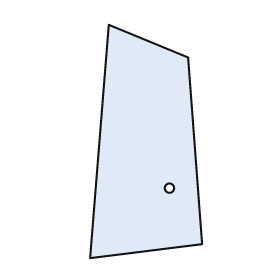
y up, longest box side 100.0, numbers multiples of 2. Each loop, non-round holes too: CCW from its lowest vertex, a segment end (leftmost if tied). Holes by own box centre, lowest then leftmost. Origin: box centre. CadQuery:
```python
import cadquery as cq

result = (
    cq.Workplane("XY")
    .moveTo(-24.0, -50.0)
    .lineTo(24.0, -44.0)
    .lineTo(18.0, 36.0)
    .lineTo(-16.0, 50.0)
    .close()
    .moveTo(10.0, -20.0)
    .circle(2.0)
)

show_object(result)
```